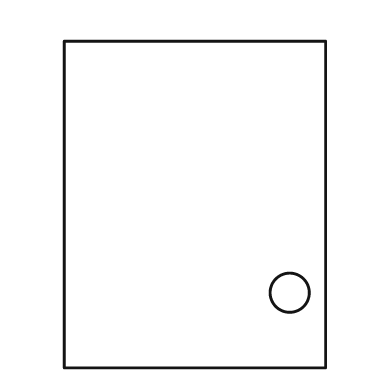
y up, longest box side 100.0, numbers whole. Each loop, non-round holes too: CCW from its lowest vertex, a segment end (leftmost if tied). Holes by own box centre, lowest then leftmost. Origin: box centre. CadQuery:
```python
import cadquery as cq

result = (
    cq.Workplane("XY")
    .moveTo(-40.0, -50.0)
    .lineTo(40.0, -50.0)
    .lineTo(40.0, 50.0)
    .lineTo(-40.0, 50.0)
    .close()
    .moveTo(29.0, -27.0)
    .circle(6.0)
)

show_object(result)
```